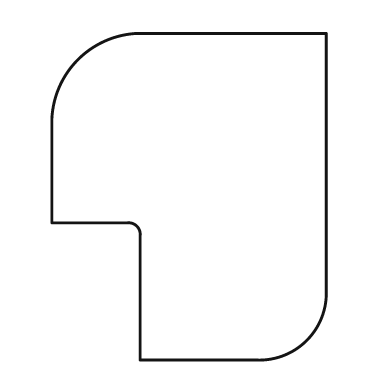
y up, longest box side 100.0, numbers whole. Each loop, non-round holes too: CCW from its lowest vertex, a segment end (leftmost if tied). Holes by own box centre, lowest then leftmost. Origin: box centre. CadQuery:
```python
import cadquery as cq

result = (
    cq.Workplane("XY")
    .moveTo(-15.0, -50.0)
    .lineTo(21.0, -50.0)
    .threePointArc((36.0, -44.0), (42.0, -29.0))
    .lineTo(42.0, 50.0)
    .lineTo(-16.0, 50.0)
    .threePointArc((-34.0, 42.0), (-42.0, 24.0))
    .lineTo(-42.0, -8.0)
    .lineTo(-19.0, -8.0)
    .threePointArc((-16.0, -9.0), (-15.0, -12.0))
    .close()
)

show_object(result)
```